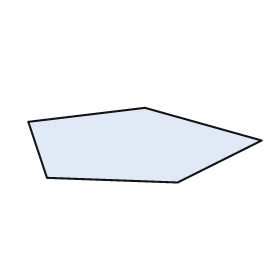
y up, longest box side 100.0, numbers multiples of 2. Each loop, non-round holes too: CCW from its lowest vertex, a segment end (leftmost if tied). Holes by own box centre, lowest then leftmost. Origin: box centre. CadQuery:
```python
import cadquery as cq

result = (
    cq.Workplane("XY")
    .moveTo(14.0, -16.0)
    .lineTo(50.0, 2.0)
    .lineTo(0.0, 16.0)
    .lineTo(-50.0, 10.0)
    .lineTo(-42.0, -14.0)
    .close()
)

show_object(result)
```